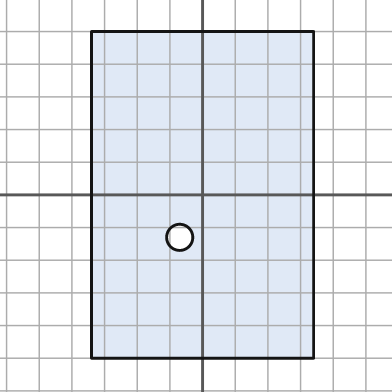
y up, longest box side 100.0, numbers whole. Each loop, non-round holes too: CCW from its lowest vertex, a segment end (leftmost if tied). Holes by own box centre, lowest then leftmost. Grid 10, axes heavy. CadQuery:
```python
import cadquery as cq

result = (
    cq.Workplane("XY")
    .moveTo(-34.0, -50.0)
    .lineTo(34.0, -50.0)
    .lineTo(34.0, 50.0)
    .lineTo(-34.0, 50.0)
    .close()
    .moveTo(-7.0, -13.0)
    .circle(4.0)
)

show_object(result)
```